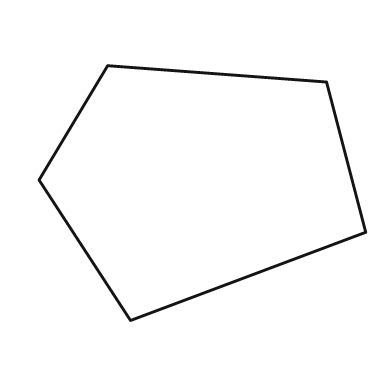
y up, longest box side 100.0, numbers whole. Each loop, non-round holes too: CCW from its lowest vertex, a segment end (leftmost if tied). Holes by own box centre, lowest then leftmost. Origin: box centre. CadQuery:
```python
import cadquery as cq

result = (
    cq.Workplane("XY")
    .moveTo(-22.0, -39.0)
    .lineTo(50.0, -12.0)
    .lineTo(38.0, 34.0)
    .lineTo(-29.0, 39.0)
    .lineTo(-50.0, 4.0)
    .close()
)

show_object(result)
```